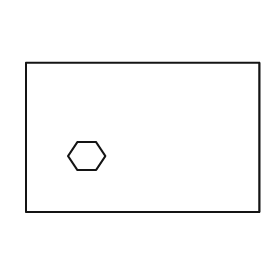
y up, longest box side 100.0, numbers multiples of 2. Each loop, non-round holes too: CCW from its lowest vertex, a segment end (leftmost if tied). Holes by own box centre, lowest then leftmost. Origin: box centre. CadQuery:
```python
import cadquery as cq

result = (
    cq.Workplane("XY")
    .moveTo(-50.0, -32.0)
    .lineTo(50.0, -32.0)
    .lineTo(50.0, 32.0)
    .lineTo(-50.0, 32.0)
    .close()
    .moveTo(-28.0, -14.0)
    .lineTo(-20.0, -14.0)
    .lineTo(-16.0, -8.0)
    .lineTo(-20.0, -2.0)
    .lineTo(-28.0, -2.0)
    .lineTo(-32.0, -8.0)
    .close()
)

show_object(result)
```